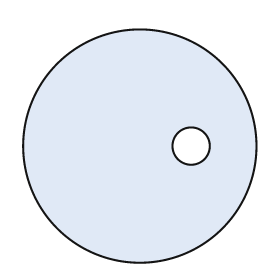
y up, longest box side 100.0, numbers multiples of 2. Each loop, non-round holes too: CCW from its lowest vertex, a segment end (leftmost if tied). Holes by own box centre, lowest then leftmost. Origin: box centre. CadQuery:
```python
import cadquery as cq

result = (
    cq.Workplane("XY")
    .moveTo(0.0, 0.0)
    .circle(50.0)
    .moveTo(22.0, 0.0)
    .circle(8.0)
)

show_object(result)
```